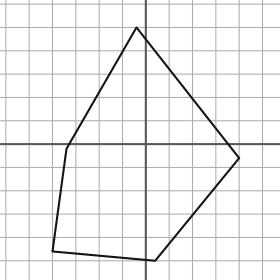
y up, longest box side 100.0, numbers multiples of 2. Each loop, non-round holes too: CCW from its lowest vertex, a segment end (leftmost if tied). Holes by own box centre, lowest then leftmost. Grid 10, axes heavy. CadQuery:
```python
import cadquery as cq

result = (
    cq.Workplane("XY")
    .moveTo(4.0, -50.0)
    .lineTo(40.0, -6.0)
    .lineTo(-4.0, 50.0)
    .lineTo(-34.0, -2.0)
    .lineTo(-40.0, -46.0)
    .close()
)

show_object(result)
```